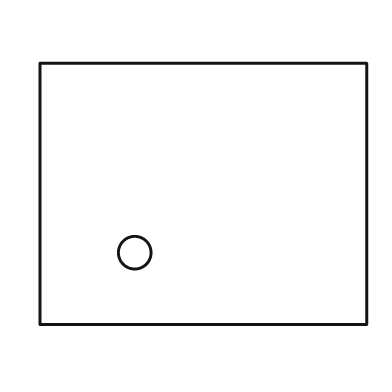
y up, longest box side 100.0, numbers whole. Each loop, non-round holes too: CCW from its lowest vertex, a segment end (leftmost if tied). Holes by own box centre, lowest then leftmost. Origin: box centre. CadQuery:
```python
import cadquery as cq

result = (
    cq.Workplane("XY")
    .moveTo(-50.0, -40.0)
    .lineTo(50.0, -40.0)
    .lineTo(50.0, 40.0)
    .lineTo(-50.0, 40.0)
    .close()
    .moveTo(-21.0, -18.0)
    .circle(5.0)
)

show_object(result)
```